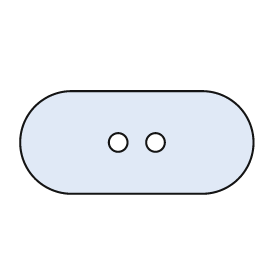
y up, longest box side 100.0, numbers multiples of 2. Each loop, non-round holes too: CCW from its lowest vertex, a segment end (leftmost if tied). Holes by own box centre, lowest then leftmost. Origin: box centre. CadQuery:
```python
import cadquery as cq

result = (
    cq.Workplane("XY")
    .moveTo(-28.0, -22.0)
    .lineTo(28.0, -22.0)
    .threePointArc((50.0, 0.0), (28.0, 22.0))
    .lineTo(-28.0, 22.0)
    .threePointArc((-50.0, 0.0), (-28.0, -22.0))
    .close()
    .moveTo(-8.0, 0.0)
    .circle(4.0)
    .moveTo(8.0, 0.0)
    .circle(4.0)
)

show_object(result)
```